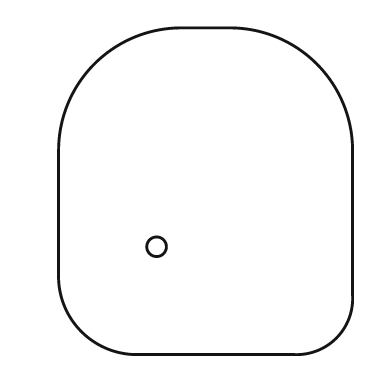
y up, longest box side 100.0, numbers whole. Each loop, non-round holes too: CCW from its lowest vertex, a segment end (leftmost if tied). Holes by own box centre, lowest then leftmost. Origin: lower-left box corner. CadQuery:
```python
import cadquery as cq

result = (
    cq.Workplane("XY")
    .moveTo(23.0, 0.0)
    .lineTo(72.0, 0.0)
    .threePointArc((85.0, 5.0), (90.0, 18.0))
    .lineTo(90.0, 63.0)
    .threePointArc((79.0, 89.0), (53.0, 100.0))
    .lineTo(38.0, 100.0)
    .threePointArc((11.0, 89.0), (0.0, 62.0))
    .lineTo(0.0, 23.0)
    .threePointArc((7.0, 7.0), (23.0, 0.0))
    .close()
    .moveTo(30.0, 33.0)
    .circle(3.0)
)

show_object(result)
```